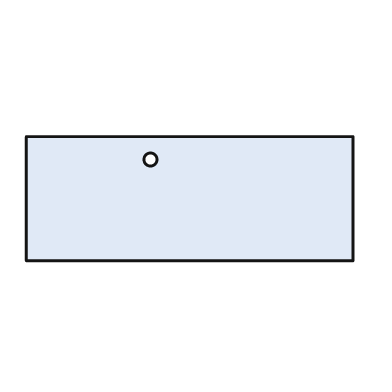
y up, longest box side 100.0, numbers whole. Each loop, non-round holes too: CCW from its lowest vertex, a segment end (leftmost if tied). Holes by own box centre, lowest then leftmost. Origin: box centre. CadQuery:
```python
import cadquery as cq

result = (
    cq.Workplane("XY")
    .moveTo(-50.0, -19.0)
    .lineTo(50.0, -19.0)
    .lineTo(50.0, 19.0)
    .lineTo(-50.0, 19.0)
    .close()
    .moveTo(-12.0, 12.0)
    .circle(2.0)
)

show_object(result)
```